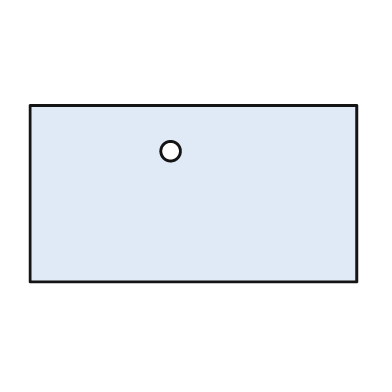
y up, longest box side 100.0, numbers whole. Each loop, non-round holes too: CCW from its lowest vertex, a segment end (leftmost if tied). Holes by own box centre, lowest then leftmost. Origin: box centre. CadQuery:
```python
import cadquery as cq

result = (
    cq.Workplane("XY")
    .moveTo(-50.0, -27.0)
    .lineTo(50.0, -27.0)
    .lineTo(50.0, 27.0)
    .lineTo(-50.0, 27.0)
    .close()
    .moveTo(-7.0, 13.0)
    .circle(3.0)
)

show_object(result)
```